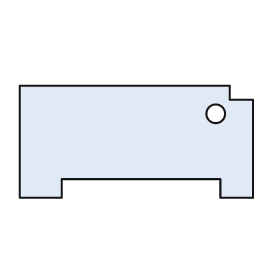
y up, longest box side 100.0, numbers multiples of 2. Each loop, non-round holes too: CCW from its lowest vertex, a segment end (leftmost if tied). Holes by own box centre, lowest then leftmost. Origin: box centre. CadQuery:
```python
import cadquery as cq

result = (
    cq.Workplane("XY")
    .moveTo(-50.0, -24.0)
    .lineTo(-32.0, -24.0)
    .lineTo(-32.0, -16.0)
    .lineTo(36.0, -16.0)
    .lineTo(36.0, -24.0)
    .lineTo(50.0, -24.0)
    .lineTo(50.0, 18.0)
    .lineTo(40.0, 18.0)
    .lineTo(40.0, 24.0)
    .lineTo(-50.0, 24.0)
    .close()
    .moveTo(34.0, 12.0)
    .circle(4.0)
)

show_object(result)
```